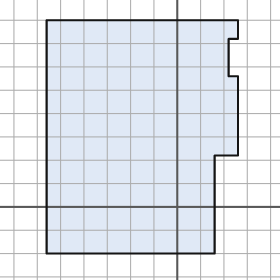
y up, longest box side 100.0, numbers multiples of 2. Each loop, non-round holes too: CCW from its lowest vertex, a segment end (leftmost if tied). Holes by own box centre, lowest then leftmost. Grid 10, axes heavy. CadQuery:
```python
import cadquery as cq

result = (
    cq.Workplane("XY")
    .moveTo(-56.0, -20.0)
    .lineTo(16.0, -20.0)
    .lineTo(16.0, 22.0)
    .lineTo(26.0, 22.0)
    .lineTo(26.0, 56.0)
    .lineTo(22.0, 56.0)
    .lineTo(22.0, 72.0)
    .lineTo(26.0, 72.0)
    .lineTo(26.0, 80.0)
    .lineTo(-56.0, 80.0)
    .close()
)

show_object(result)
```